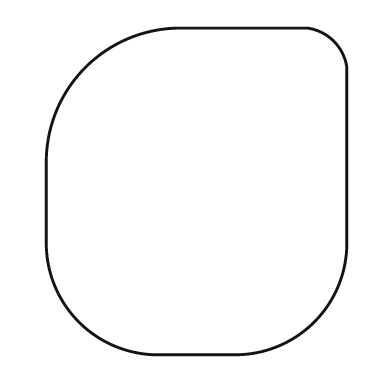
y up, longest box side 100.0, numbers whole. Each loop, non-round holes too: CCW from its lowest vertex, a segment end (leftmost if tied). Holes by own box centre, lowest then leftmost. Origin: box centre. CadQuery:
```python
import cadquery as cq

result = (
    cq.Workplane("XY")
    .moveTo(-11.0, -50.0)
    .lineTo(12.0, -50.0)
    .threePointArc((36.0, -40.0), (46.0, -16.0))
    .lineTo(46.0, 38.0)
    .threePointArc((42.0, 46.0), (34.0, 50.0))
    .lineTo(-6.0, 50.0)
    .threePointArc((-34.0, 38.0), (-46.0, 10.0))
    .lineTo(-46.0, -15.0)
    .threePointArc((-36.0, -40.0), (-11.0, -50.0))
    .close()
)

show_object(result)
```